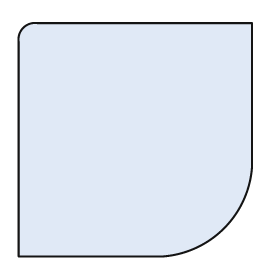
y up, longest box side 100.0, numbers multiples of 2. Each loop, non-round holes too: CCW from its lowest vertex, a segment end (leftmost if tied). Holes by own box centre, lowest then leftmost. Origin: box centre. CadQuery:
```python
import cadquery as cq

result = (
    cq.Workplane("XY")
    .moveTo(-50.0, -50.0)
    .lineTo(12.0, -50.0)
    .threePointArc((38.0, -38.0), (50.0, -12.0))
    .lineTo(50.0, 50.0)
    .lineTo(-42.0, 50.0)
    .threePointArc((-48.0, 48.0), (-50.0, 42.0))
    .close()
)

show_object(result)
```